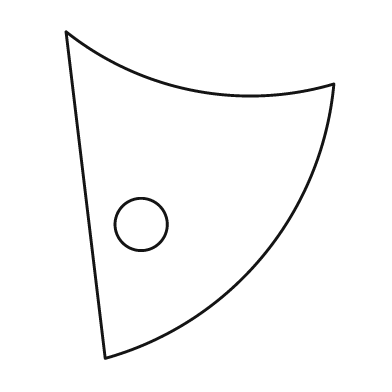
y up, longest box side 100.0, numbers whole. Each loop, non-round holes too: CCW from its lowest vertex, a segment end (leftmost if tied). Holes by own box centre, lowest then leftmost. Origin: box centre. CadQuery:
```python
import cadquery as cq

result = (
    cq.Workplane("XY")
    .moveTo(-29.0, -50.0)
    .threePointArc((19.0, -19.0), (41.0, 34.0))
    .threePointArc((-2.0, 32.0), (-41.0, 50.0))
    .close()
    .moveTo(-18.0, -9.0)
    .circle(8.0)
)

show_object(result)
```